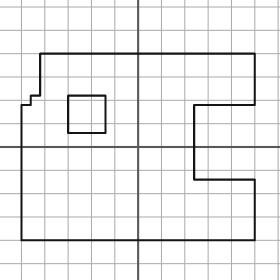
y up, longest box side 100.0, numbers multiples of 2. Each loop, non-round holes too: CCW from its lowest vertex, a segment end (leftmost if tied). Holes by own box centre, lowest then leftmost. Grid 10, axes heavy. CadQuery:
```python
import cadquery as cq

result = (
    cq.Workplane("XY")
    .moveTo(-50.0, -40.0)
    .lineTo(50.0, -40.0)
    .lineTo(50.0, -14.0)
    .lineTo(24.0, -14.0)
    .lineTo(24.0, 18.0)
    .lineTo(50.0, 18.0)
    .lineTo(50.0, 40.0)
    .lineTo(-42.0, 40.0)
    .lineTo(-42.0, 22.0)
    .lineTo(-46.0, 22.0)
    .lineTo(-46.0, 18.0)
    .lineTo(-50.0, 18.0)
    .close()
    .moveTo(-30.0, 6.0)
    .lineTo(-14.0, 6.0)
    .lineTo(-14.0, 22.0)
    .lineTo(-30.0, 22.0)
    .close()
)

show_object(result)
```